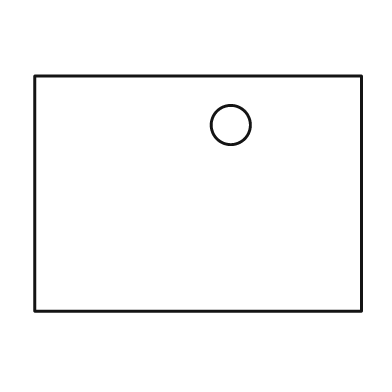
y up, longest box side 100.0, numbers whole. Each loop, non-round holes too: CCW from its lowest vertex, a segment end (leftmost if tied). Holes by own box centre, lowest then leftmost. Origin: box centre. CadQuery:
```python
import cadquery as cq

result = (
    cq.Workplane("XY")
    .moveTo(-50.0, -36.0)
    .lineTo(50.0, -36.0)
    .lineTo(50.0, 36.0)
    .lineTo(-50.0, 36.0)
    .close()
    .moveTo(10.0, 21.0)
    .circle(6.0)
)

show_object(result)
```